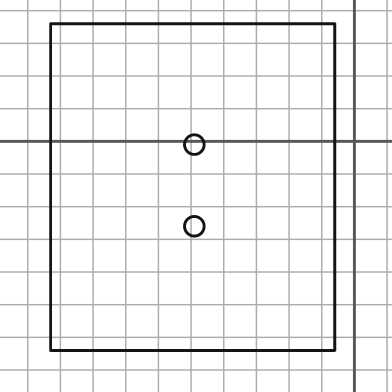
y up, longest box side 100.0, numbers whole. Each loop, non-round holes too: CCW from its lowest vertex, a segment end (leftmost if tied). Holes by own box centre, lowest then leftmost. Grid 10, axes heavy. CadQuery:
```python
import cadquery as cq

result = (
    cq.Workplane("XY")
    .moveTo(-93.0, -64.0)
    .lineTo(-6.0, -64.0)
    .lineTo(-6.0, 36.0)
    .lineTo(-93.0, 36.0)
    .close()
    .moveTo(-49.0, -26.0)
    .circle(3.0)
    .moveTo(-49.0, -1.0)
    .circle(3.0)
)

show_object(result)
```